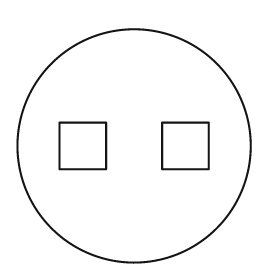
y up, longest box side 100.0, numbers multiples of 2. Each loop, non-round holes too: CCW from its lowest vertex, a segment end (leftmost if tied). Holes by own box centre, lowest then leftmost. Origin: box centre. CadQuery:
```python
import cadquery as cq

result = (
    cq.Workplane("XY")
    .moveTo(0.0, 0.0)
    .circle(50.0)
    .moveTo(-32.0, -10.0)
    .lineTo(-12.0, -10.0)
    .lineTo(-12.0, 10.0)
    .lineTo(-32.0, 10.0)
    .close()
    .moveTo(12.0, -10.0)
    .lineTo(32.0, -10.0)
    .lineTo(32.0, 10.0)
    .lineTo(12.0, 10.0)
    .close()
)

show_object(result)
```